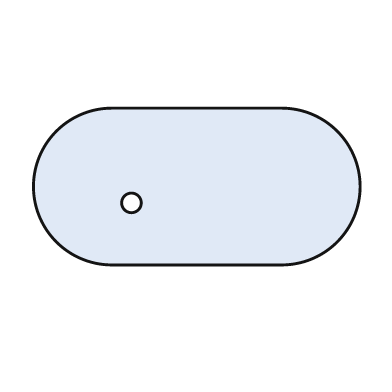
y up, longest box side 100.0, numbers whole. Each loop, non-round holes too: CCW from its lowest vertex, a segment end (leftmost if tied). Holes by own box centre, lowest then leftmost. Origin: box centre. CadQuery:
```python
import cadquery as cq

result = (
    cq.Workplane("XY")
    .moveTo(-26.0, -24.0)
    .lineTo(26.0, -24.0)
    .threePointArc((50.0, 0.0), (26.0, 24.0))
    .lineTo(-26.0, 24.0)
    .threePointArc((-50.0, 0.0), (-26.0, -24.0))
    .close()
    .moveTo(-20.0, -5.0)
    .circle(3.0)
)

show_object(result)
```